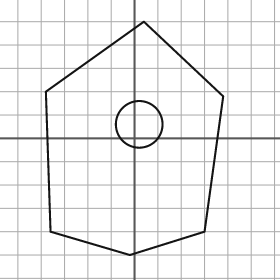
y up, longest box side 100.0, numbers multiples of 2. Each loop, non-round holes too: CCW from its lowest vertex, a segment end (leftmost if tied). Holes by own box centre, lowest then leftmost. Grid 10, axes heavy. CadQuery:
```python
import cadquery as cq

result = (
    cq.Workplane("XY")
    .moveTo(-2.0, -50.0)
    .lineTo(30.0, -40.0)
    .lineTo(38.0, 18.0)
    .lineTo(4.0, 50.0)
    .lineTo(-38.0, 20.0)
    .lineTo(-36.0, -40.0)
    .close()
    .moveTo(2.0, 6.0)
    .circle(10.0)
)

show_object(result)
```